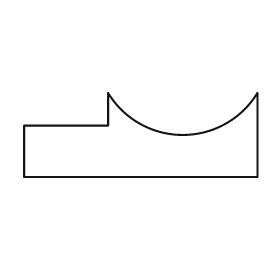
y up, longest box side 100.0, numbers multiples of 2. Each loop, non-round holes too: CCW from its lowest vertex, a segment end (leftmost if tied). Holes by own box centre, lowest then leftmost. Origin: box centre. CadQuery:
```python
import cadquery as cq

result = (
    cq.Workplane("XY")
    .moveTo(-50.0, -18.0)
    .lineTo(50.0, -18.0)
    .lineTo(50.0, 18.0)
    .threePointArc((18.0, 0.0), (-14.0, 18.0))
    .lineTo(-14.0, 4.0)
    .lineTo(-50.0, 4.0)
    .close()
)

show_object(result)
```